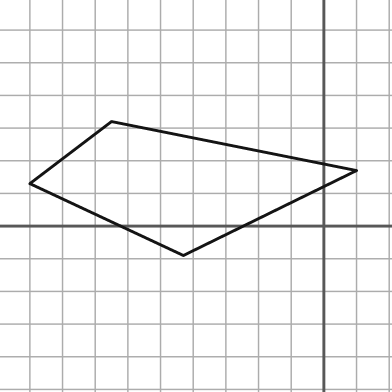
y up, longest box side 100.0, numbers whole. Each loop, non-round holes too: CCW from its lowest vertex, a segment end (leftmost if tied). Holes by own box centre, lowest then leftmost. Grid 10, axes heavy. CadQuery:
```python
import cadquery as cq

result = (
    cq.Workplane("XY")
    .moveTo(-43.0, -9.0)
    .lineTo(10.0, 17.0)
    .lineTo(-65.0, 32.0)
    .lineTo(-90.0, 13.0)
    .close()
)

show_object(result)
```